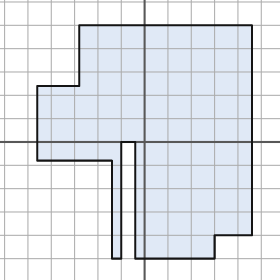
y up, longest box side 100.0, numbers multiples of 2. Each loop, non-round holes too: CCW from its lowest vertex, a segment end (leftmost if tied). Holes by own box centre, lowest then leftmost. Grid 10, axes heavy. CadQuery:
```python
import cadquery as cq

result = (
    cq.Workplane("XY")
    .moveTo(-14.0, -50.0)
    .lineTo(-10.0, -50.0)
    .lineTo(-10.0, 0.0)
    .lineTo(-4.0, 0.0)
    .lineTo(-4.0, -50.0)
    .lineTo(30.0, -50.0)
    .lineTo(30.0, -40.0)
    .lineTo(46.0, -40.0)
    .lineTo(46.0, 50.0)
    .lineTo(-28.0, 50.0)
    .lineTo(-28.0, 24.0)
    .lineTo(-46.0, 24.0)
    .lineTo(-46.0, -8.0)
    .lineTo(-14.0, -8.0)
    .close()
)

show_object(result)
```